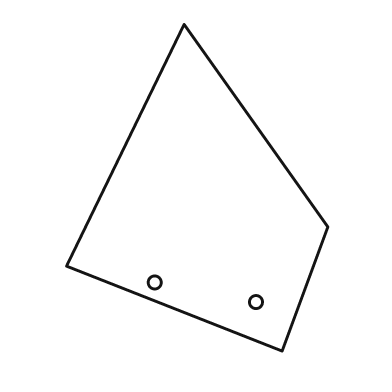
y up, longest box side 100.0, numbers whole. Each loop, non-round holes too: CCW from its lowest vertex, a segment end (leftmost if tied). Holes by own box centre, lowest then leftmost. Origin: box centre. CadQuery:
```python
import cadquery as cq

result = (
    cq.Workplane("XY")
    .moveTo(26.0, -50.0)
    .lineTo(40.0, -12.0)
    .lineTo(-4.0, 50.0)
    .lineTo(-40.0, -24.0)
    .close()
    .moveTo(18.0, -35.0)
    .circle(2.0)
    .moveTo(-13.0, -29.0)
    .circle(2.0)
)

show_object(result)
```